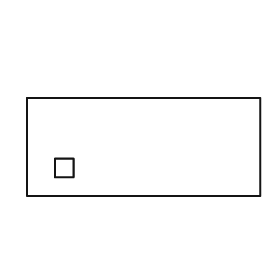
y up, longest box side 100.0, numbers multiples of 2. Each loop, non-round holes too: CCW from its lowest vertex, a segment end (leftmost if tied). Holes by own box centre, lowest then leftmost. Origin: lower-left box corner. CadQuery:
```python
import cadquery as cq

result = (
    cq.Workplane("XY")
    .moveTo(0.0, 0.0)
    .lineTo(100.0, 0.0)
    .lineTo(100.0, 42.0)
    .lineTo(0.0, 42.0)
    .close()
    .moveTo(12.0, 8.0)
    .lineTo(20.0, 8.0)
    .lineTo(20.0, 16.0)
    .lineTo(12.0, 16.0)
    .close()
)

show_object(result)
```